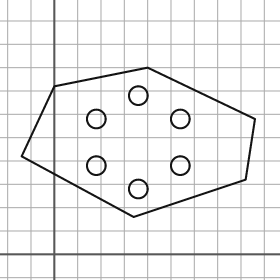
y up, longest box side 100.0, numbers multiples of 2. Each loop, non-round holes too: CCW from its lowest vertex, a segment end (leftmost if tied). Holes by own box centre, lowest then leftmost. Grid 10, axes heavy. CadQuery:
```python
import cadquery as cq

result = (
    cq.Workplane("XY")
    .moveTo(34.0, 16.0)
    .lineTo(82.0, 32.0)
    .lineTo(86.0, 58.0)
    .lineTo(40.0, 80.0)
    .lineTo(0.0, 72.0)
    .lineTo(-14.0, 42.0)
    .close()
    .moveTo(36.0, 28.0)
    .circle(4.0)
    .moveTo(18.0, 38.0)
    .circle(4.0)
    .moveTo(54.0, 38.0)
    .circle(4.0)
    .moveTo(18.0, 58.0)
    .circle(4.0)
    .moveTo(54.0, 58.0)
    .circle(4.0)
    .moveTo(36.0, 68.0)
    .circle(4.0)
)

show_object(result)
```